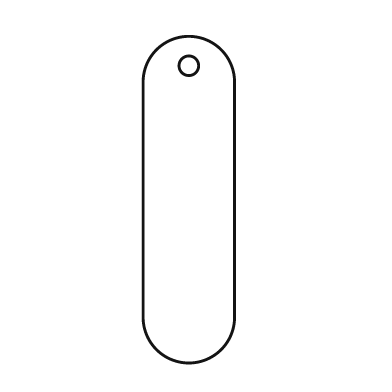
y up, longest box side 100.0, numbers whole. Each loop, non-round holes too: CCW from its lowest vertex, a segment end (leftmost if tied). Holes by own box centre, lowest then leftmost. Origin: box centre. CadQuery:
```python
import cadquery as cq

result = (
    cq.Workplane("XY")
    .moveTo(-14.0, -36.0)
    .threePointArc((0.0, -50.0), (14.0, -36.0))
    .lineTo(14.0, 36.0)
    .threePointArc((0.0, 50.0), (-14.0, 36.0))
    .close()
    .moveTo(0.0, 41.0)
    .circle(3.0)
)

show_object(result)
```